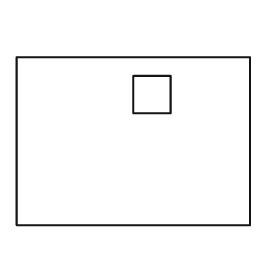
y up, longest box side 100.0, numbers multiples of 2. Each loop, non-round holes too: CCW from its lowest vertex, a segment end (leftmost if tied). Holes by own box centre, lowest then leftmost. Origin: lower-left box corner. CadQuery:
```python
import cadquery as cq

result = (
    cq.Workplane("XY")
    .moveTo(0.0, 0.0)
    .lineTo(100.0, 0.0)
    .lineTo(100.0, 72.0)
    .lineTo(0.0, 72.0)
    .close()
    .moveTo(50.0, 48.0)
    .lineTo(66.0, 48.0)
    .lineTo(66.0, 64.0)
    .lineTo(50.0, 64.0)
    .close()
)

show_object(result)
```